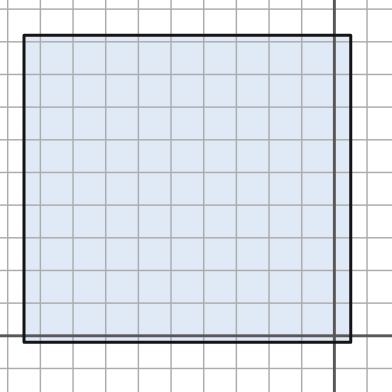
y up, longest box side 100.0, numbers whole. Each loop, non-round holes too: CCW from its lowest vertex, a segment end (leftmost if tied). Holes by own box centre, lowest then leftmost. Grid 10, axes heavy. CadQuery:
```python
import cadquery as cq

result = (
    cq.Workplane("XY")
    .moveTo(-95.0, -2.0)
    .lineTo(5.0, -2.0)
    .lineTo(5.0, 92.0)
    .lineTo(-95.0, 92.0)
    .close()
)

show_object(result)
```